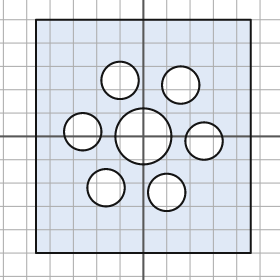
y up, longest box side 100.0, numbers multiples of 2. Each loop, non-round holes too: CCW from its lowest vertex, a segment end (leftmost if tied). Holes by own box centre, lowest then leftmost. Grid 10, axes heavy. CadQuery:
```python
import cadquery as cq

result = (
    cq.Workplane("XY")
    .moveTo(-46.0, -50.0)
    .lineTo(46.0, -50.0)
    .lineTo(46.0, 50.0)
    .lineTo(-46.0, 50.0)
    .close()
    .moveTo(10.0, -24.0)
    .circle(8.0)
    .moveTo(-16.0, -22.0)
    .circle(8.0)
    .moveTo(26.0, -2.0)
    .circle(8.0)
    .moveTo(0.0, 0.0)
    .circle(12.0)
    .moveTo(-26.0, 2.0)
    .circle(8.0)
    .moveTo(16.0, 22.0)
    .circle(8.0)
    .moveTo(-10.0, 24.0)
    .circle(8.0)
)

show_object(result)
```